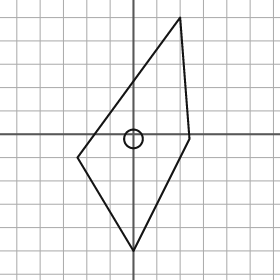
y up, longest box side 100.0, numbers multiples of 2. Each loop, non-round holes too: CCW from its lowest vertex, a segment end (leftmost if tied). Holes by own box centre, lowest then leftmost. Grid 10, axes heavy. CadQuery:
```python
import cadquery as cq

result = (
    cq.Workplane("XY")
    .moveTo(0.0, -50.0)
    .lineTo(24.0, -2.0)
    .lineTo(20.0, 50.0)
    .lineTo(-24.0, -10.0)
    .close()
    .moveTo(0.0, -2.0)
    .circle(4.0)
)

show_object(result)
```